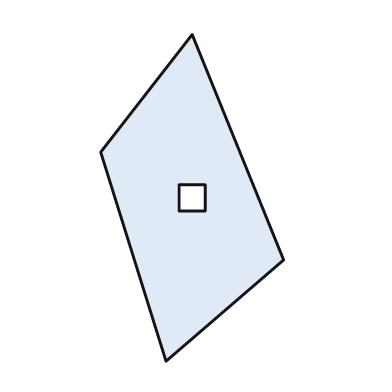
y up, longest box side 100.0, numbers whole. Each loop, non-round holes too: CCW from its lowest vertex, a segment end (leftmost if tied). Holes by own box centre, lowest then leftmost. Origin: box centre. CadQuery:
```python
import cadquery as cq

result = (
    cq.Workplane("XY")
    .moveTo(-8.0, -50.0)
    .lineTo(28.0, -19.0)
    .lineTo(0.0, 50.0)
    .lineTo(-28.0, 14.0)
    .close()
    .moveTo(-4.0, -4.0)
    .lineTo(4.0, -4.0)
    .lineTo(4.0, 4.0)
    .lineTo(-4.0, 4.0)
    .close()
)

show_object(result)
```